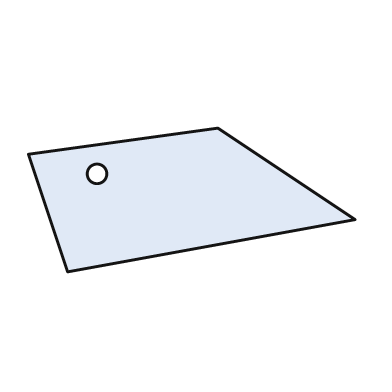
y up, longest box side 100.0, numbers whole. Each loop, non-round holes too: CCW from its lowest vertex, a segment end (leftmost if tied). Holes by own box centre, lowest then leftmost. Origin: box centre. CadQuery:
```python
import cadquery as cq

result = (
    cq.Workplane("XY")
    .moveTo(-38.0, -22.0)
    .lineTo(50.0, -6.0)
    .lineTo(8.0, 22.0)
    .lineTo(-50.0, 14.0)
    .close()
    .moveTo(-29.0, 8.0)
    .circle(3.0)
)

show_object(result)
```